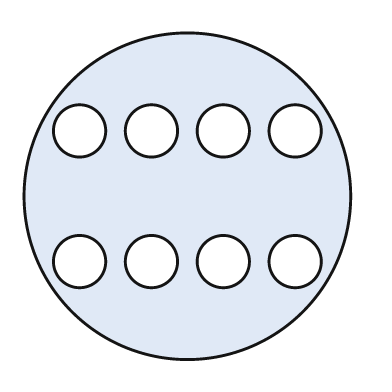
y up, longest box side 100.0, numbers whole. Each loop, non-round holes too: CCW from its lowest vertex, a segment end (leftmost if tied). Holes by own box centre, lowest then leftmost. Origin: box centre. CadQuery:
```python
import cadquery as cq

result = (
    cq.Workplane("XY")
    .moveTo(0.0, 0.0)
    .circle(50.0)
    .moveTo(-33.0, -20.0)
    .circle(8.0)
    .moveTo(-11.0, -20.0)
    .circle(8.0)
    .moveTo(11.0, -20.0)
    .circle(8.0)
    .moveTo(33.0, -20.0)
    .circle(8.0)
    .moveTo(-33.0, 20.0)
    .circle(8.0)
    .moveTo(-11.0, 20.0)
    .circle(8.0)
    .moveTo(11.0, 20.0)
    .circle(8.0)
    .moveTo(33.0, 20.0)
    .circle(8.0)
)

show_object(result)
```